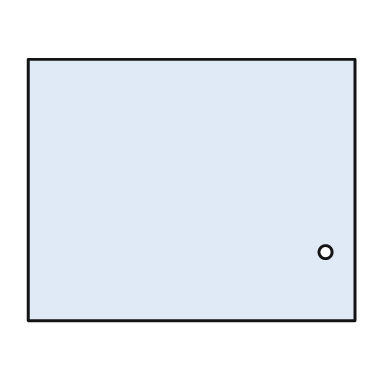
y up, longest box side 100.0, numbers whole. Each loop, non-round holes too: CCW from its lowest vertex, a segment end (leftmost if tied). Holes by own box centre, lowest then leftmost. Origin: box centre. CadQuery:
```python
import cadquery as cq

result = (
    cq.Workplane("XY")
    .moveTo(-50.0, -40.0)
    .lineTo(50.0, -40.0)
    .lineTo(50.0, 40.0)
    .lineTo(-50.0, 40.0)
    .close()
    .moveTo(41.0, -19.0)
    .circle(2.0)
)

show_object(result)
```